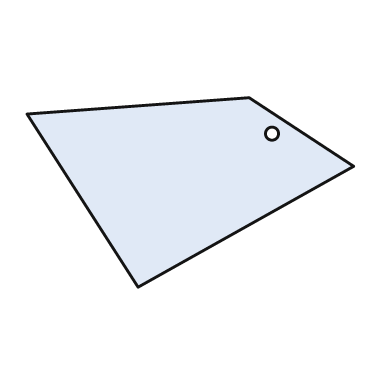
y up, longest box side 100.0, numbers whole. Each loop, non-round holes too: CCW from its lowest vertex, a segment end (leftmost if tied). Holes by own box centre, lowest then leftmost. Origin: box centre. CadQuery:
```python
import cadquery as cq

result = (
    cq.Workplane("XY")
    .moveTo(-16.0, -29.0)
    .lineTo(50.0, 8.0)
    .lineTo(18.0, 29.0)
    .lineTo(-50.0, 24.0)
    .close()
    .moveTo(25.0, 18.0)
    .circle(2.0)
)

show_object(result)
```